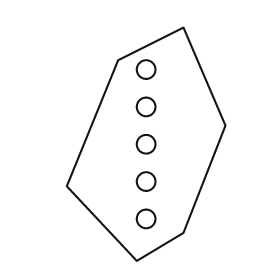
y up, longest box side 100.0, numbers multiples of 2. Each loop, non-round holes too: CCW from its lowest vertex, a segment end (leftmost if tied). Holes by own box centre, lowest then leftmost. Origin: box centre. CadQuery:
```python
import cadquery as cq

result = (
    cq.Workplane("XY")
    .moveTo(-4.0, -50.0)
    .lineTo(16.0, -38.0)
    .lineTo(34.0, 8.0)
    .lineTo(16.0, 50.0)
    .lineTo(-12.0, 36.0)
    .lineTo(-34.0, -18.0)
    .close()
    .moveTo(0.0, -32.0)
    .circle(4.0)
    .moveTo(0.0, -16.0)
    .circle(4.0)
    .moveTo(0.0, 0.0)
    .circle(4.0)
    .moveTo(0.0, 16.0)
    .circle(4.0)
    .moveTo(0.0, 32.0)
    .circle(4.0)
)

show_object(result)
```